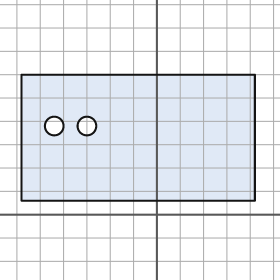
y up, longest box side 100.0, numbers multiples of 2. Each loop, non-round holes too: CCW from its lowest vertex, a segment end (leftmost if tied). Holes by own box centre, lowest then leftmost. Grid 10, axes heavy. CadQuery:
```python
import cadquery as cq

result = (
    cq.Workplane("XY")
    .moveTo(-58.0, 6.0)
    .lineTo(42.0, 6.0)
    .lineTo(42.0, 60.0)
    .lineTo(-58.0, 60.0)
    .close()
    .moveTo(-44.0, 38.0)
    .circle(4.0)
    .moveTo(-30.0, 38.0)
    .circle(4.0)
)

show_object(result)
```